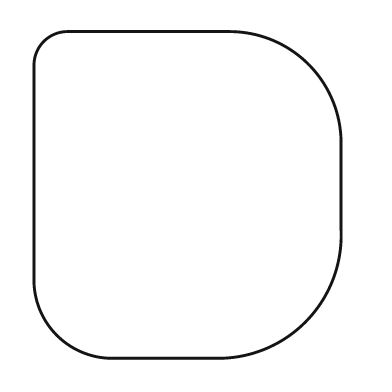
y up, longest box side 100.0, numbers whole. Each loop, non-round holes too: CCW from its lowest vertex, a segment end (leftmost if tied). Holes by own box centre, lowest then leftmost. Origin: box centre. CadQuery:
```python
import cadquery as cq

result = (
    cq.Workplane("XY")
    .moveTo(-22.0, -50.0)
    .lineTo(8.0, -50.0)
    .threePointArc((36.0, -39.0), (47.0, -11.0))
    .lineTo(47.0, 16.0)
    .threePointArc((37.0, 40.0), (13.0, 50.0))
    .lineTo(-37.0, 50.0)
    .threePointArc((-44.0, 47.0), (-47.0, 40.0))
    .lineTo(-47.0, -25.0)
    .threePointArc((-40.0, -43.0), (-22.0, -50.0))
    .close()
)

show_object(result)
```